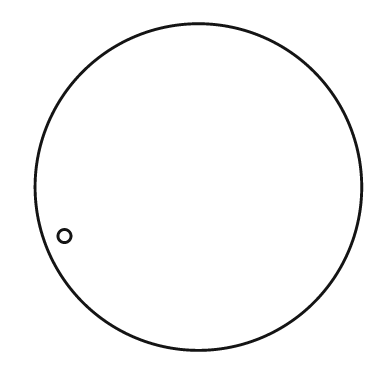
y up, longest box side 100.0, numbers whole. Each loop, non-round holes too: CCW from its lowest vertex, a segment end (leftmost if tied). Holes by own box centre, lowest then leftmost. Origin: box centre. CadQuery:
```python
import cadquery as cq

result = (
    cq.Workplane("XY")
    .moveTo(0.0, 0.0)
    .circle(50.0)
    .moveTo(-41.0, -15.0)
    .circle(2.0)
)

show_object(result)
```